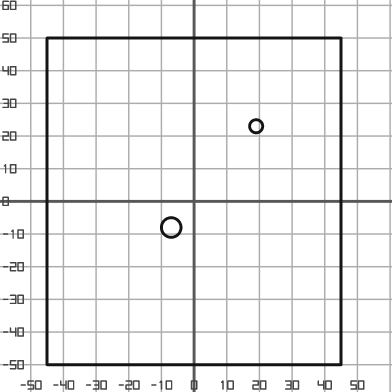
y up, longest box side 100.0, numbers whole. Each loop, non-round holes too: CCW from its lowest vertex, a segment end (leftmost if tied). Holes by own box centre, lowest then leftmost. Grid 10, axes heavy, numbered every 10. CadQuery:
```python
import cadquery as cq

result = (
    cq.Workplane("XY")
    .moveTo(-45.0, -50.0)
    .lineTo(45.0, -50.0)
    .lineTo(45.0, 50.0)
    .lineTo(-45.0, 50.0)
    .close()
    .moveTo(-7.0, -8.0)
    .circle(3.0)
    .moveTo(19.0, 23.0)
    .circle(2.0)
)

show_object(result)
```